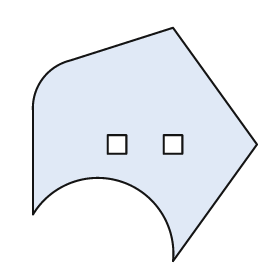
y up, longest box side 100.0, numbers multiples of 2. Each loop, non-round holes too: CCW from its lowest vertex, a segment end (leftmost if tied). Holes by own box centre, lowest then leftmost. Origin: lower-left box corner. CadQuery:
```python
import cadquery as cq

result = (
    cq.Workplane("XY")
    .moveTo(60.0, 0.0)
    .lineTo(96.0, 50.0)
    .lineTo(60.0, 100.0)
    .lineTo(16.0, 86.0)
    .threePointArc((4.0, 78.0), (0.0, 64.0))
    .lineTo(0.0, 20.0)
    .threePointArc((38.0, 34.0), (60.0, 0.0))
    .close()
    .moveTo(32.0, 46.0)
    .lineTo(40.0, 46.0)
    .lineTo(40.0, 54.0)
    .lineTo(32.0, 54.0)
    .close()
    .moveTo(56.0, 46.0)
    .lineTo(64.0, 46.0)
    .lineTo(64.0, 54.0)
    .lineTo(56.0, 54.0)
    .close()
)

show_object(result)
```